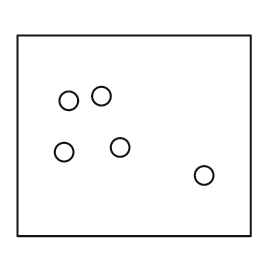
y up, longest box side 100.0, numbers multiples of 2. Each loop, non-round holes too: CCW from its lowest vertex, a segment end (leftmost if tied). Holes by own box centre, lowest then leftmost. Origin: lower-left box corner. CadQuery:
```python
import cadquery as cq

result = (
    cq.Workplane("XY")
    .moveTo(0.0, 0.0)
    .lineTo(100.0, 0.0)
    .lineTo(100.0, 86.0)
    .lineTo(0.0, 86.0)
    .close()
    .moveTo(80.0, 26.0)
    .circle(4.0)
    .moveTo(20.0, 36.0)
    .circle(4.0)
    .moveTo(44.0, 38.0)
    .circle(4.0)
    .moveTo(22.0, 58.0)
    .circle(4.0)
    .moveTo(36.0, 60.0)
    .circle(4.0)
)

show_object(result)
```